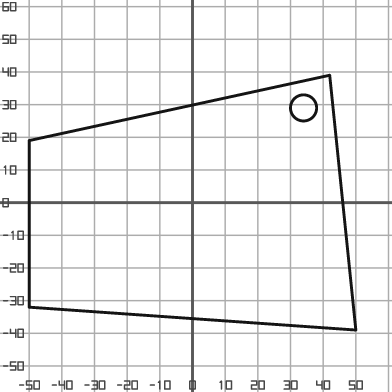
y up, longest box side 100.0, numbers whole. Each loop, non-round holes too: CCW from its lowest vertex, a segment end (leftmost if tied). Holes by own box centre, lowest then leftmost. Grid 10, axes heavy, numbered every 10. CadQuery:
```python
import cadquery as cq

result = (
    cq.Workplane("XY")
    .moveTo(50.0, -39.0)
    .lineTo(42.0, 39.0)
    .lineTo(-50.0, 19.0)
    .lineTo(-50.0, -32.0)
    .close()
    .moveTo(34.0, 29.0)
    .circle(4.0)
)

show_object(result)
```